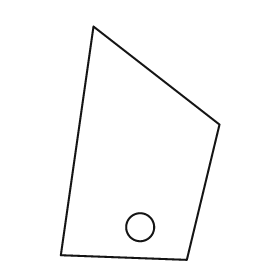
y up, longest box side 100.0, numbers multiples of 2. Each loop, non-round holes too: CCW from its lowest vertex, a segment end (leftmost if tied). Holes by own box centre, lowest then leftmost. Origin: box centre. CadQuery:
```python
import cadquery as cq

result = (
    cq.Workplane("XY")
    .moveTo(20.0, -50.0)
    .lineTo(34.0, 8.0)
    .lineTo(-20.0, 50.0)
    .lineTo(-34.0, -48.0)
    .close()
    .moveTo(0.0, -36.0)
    .circle(6.0)
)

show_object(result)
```